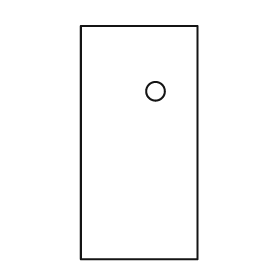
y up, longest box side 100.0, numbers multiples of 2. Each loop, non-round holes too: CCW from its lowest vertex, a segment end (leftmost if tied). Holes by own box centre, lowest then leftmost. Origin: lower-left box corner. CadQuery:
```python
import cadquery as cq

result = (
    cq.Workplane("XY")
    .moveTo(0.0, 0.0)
    .lineTo(50.0, 0.0)
    .lineTo(50.0, 100.0)
    .lineTo(0.0, 100.0)
    .close()
    .moveTo(32.0, 72.0)
    .circle(4.0)
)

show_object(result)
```